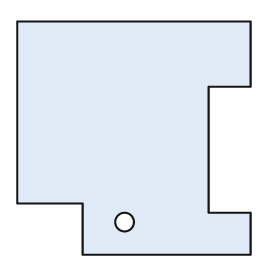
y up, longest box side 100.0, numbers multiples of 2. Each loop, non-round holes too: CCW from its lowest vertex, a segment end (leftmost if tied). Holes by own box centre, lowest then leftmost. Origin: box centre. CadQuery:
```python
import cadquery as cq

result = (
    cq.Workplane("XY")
    .moveTo(-22.0, -50.0)
    .lineTo(50.0, -50.0)
    .lineTo(50.0, -32.0)
    .lineTo(32.0, -32.0)
    .lineTo(32.0, 22.0)
    .lineTo(50.0, 22.0)
    .lineTo(50.0, 50.0)
    .lineTo(-50.0, 50.0)
    .lineTo(-50.0, -28.0)
    .lineTo(-22.0, -28.0)
    .close()
    .moveTo(-4.0, -36.0)
    .circle(4.0)
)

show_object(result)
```